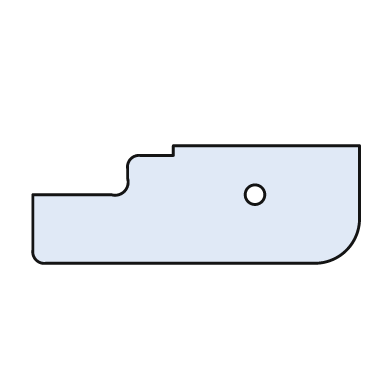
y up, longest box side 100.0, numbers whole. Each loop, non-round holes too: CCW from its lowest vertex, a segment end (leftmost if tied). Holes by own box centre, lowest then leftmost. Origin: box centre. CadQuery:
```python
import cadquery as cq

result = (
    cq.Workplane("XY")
    .moveTo(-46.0, -18.0)
    .lineTo(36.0, -18.0)
    .threePointArc((46.0, -14.0), (50.0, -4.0))
    .lineTo(50.0, 18.0)
    .lineTo(-7.0, 18.0)
    .lineTo(-7.0, 15.0)
    .lineTo(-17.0, 15.0)
    .threePointArc((-20.0, 14.0), (-21.0, 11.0))
    .lineTo(-21.0, 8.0)
    .threePointArc((-22.0, 4.0), (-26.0, 3.0))
    .lineTo(-50.0, 3.0)
    .lineTo(-50.0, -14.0)
    .threePointArc((-49.0, -17.0), (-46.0, -18.0))
    .close()
    .moveTo(18.0, 3.0)
    .circle(3.0)
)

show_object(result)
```